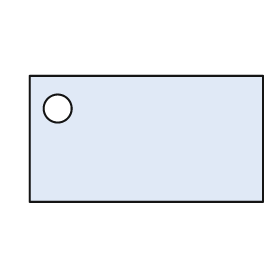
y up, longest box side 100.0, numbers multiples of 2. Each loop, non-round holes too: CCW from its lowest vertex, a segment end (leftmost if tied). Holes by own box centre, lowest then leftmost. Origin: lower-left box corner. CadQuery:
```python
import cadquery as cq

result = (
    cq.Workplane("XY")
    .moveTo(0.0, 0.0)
    .lineTo(100.0, 0.0)
    .lineTo(100.0, 54.0)
    .lineTo(0.0, 54.0)
    .close()
    .moveTo(12.0, 40.0)
    .circle(6.0)
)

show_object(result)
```